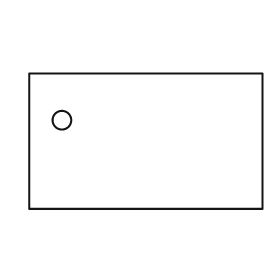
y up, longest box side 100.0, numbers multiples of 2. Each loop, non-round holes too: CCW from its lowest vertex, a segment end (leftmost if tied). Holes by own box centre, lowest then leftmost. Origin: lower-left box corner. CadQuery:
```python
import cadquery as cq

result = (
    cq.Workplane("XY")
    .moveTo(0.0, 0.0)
    .lineTo(100.0, 0.0)
    .lineTo(100.0, 58.0)
    .lineTo(0.0, 58.0)
    .close()
    .moveTo(14.0, 38.0)
    .circle(4.0)
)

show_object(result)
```